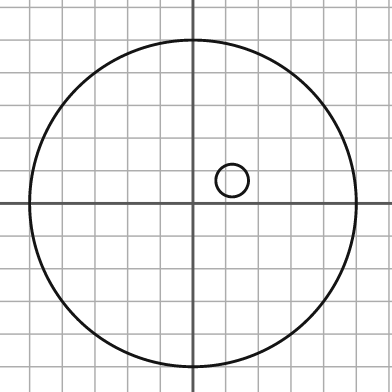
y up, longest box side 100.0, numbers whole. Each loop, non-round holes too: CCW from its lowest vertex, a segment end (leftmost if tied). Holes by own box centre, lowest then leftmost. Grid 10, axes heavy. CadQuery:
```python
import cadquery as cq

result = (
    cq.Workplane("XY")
    .moveTo(0.0, 0.0)
    .circle(50.0)
    .moveTo(12.0, 7.0)
    .circle(5.0)
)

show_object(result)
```